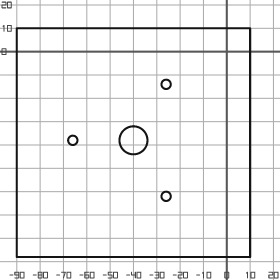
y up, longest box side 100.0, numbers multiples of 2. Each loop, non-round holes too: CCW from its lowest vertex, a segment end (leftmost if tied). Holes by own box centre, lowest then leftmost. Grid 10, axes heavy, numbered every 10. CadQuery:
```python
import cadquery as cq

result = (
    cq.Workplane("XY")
    .moveTo(-90.0, -88.0)
    .lineTo(10.0, -88.0)
    .lineTo(10.0, 10.0)
    .lineTo(-90.0, 10.0)
    .close()
    .moveTo(-26.0, -62.0)
    .circle(2.0)
    .moveTo(-66.0, -38.0)
    .circle(2.0)
    .moveTo(-40.0, -38.0)
    .circle(6.0)
    .moveTo(-26.0, -14.0)
    .circle(2.0)
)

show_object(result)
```